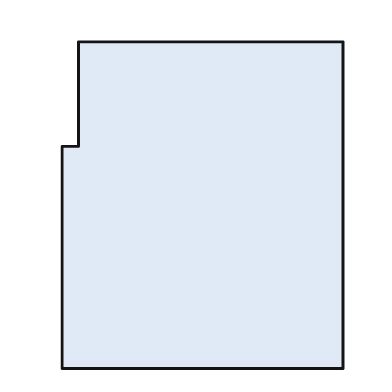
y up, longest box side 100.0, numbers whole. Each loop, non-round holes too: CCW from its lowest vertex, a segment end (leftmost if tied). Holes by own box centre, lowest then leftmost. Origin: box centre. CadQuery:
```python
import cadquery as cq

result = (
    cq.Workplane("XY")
    .moveTo(-43.0, -50.0)
    .lineTo(43.0, -50.0)
    .lineTo(43.0, 50.0)
    .lineTo(-38.0, 50.0)
    .lineTo(-38.0, 18.0)
    .lineTo(-43.0, 18.0)
    .close()
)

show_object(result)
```